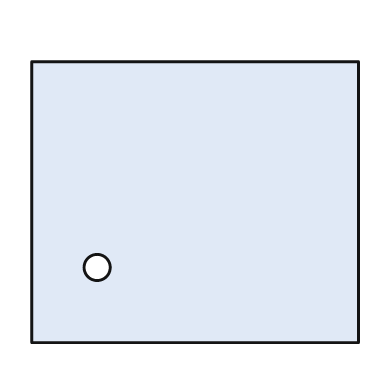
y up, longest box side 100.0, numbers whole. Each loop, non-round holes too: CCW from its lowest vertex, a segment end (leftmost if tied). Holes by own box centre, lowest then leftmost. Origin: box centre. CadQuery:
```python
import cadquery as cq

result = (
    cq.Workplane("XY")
    .moveTo(-50.0, -43.0)
    .lineTo(50.0, -43.0)
    .lineTo(50.0, 43.0)
    .lineTo(-50.0, 43.0)
    .close()
    .moveTo(-30.0, -20.0)
    .circle(4.0)
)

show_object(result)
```